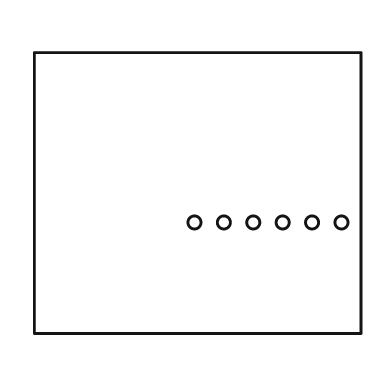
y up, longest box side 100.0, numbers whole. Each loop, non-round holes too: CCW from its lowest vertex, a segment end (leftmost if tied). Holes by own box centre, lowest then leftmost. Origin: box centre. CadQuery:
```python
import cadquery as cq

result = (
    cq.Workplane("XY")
    .moveTo(-50.0, -43.0)
    .lineTo(50.0, -43.0)
    .lineTo(50.0, 43.0)
    .lineTo(-50.0, 43.0)
    .close()
    .moveTo(-1.0, -9.0)
    .circle(2.0)
    .moveTo(8.0, -9.0)
    .circle(2.0)
    .moveTo(17.0, -9.0)
    .circle(2.0)
    .moveTo(26.0, -9.0)
    .circle(2.0)
    .moveTo(35.0, -9.0)
    .circle(2.0)
    .moveTo(44.0, -9.0)
    .circle(2.0)
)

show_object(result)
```